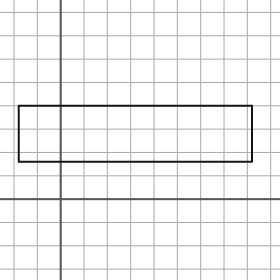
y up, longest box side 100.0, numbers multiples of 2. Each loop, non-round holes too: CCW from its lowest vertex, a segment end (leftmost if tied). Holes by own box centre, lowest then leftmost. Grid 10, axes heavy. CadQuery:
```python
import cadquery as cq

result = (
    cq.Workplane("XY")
    .moveTo(-18.0, 16.0)
    .lineTo(82.0, 16.0)
    .lineTo(82.0, 40.0)
    .lineTo(-18.0, 40.0)
    .close()
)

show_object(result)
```